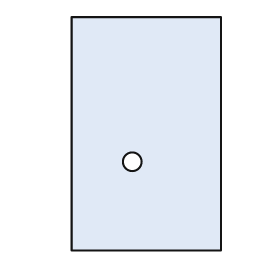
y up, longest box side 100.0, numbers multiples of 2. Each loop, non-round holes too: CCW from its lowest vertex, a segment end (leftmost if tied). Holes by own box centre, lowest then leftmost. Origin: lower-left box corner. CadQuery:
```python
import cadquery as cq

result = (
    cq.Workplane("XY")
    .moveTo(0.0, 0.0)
    .lineTo(64.0, 0.0)
    .lineTo(64.0, 100.0)
    .lineTo(0.0, 100.0)
    .close()
    .moveTo(26.0, 38.0)
    .circle(4.0)
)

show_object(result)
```